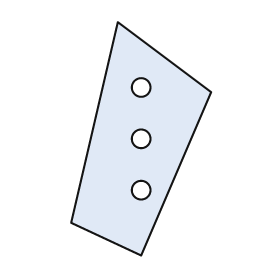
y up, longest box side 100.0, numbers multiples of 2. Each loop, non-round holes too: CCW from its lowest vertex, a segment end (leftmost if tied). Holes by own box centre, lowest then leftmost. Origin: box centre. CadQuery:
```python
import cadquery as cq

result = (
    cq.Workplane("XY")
    .moveTo(0.0, -50.0)
    .lineTo(30.0, 20.0)
    .lineTo(-10.0, 50.0)
    .lineTo(-30.0, -36.0)
    .close()
    .moveTo(0.0, -22.0)
    .circle(4.0)
    .moveTo(0.0, 0.0)
    .circle(4.0)
    .moveTo(0.0, 22.0)
    .circle(4.0)
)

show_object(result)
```